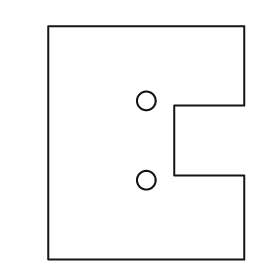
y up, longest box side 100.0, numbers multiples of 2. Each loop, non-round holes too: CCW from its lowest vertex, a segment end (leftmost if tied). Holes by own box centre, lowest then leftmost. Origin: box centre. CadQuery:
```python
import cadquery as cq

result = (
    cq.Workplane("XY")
    .moveTo(-42.0, -50.0)
    .lineTo(42.0, -50.0)
    .lineTo(42.0, -14.0)
    .lineTo(12.0, -14.0)
    .lineTo(12.0, 16.0)
    .lineTo(42.0, 16.0)
    .lineTo(42.0, 50.0)
    .lineTo(-42.0, 50.0)
    .close()
    .moveTo(0.0, -16.0)
    .circle(4.0)
    .moveTo(0.0, 18.0)
    .circle(4.0)
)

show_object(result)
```